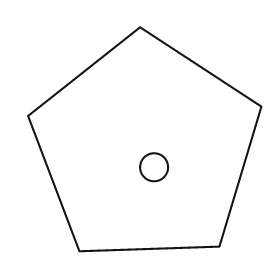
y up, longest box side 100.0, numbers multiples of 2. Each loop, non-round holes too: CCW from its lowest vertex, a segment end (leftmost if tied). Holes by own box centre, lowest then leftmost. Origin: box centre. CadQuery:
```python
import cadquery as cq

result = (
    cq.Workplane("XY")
    .moveTo(-28.0, -48.0)
    .lineTo(32.0, -46.0)
    .lineTo(50.0, 14.0)
    .lineTo(-2.0, 48.0)
    .lineTo(-50.0, 10.0)
    .close()
    .moveTo(4.0, -12.0)
    .circle(6.0)
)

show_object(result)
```